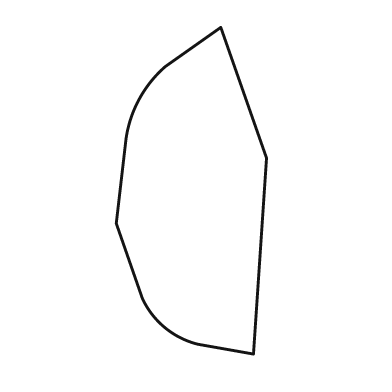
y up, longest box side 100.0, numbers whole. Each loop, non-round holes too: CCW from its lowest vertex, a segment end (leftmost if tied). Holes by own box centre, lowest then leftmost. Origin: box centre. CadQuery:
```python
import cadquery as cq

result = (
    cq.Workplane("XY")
    .moveTo(19.0, -50.0)
    .lineTo(23.0, 10.0)
    .lineTo(9.0, 50.0)
    .lineTo(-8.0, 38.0)
    .threePointArc((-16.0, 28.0), (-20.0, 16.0))
    .lineTo(-23.0, -10.0)
    .lineTo(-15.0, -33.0)
    .threePointArc((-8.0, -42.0), (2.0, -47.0))
    .close()
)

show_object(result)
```